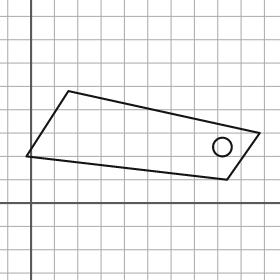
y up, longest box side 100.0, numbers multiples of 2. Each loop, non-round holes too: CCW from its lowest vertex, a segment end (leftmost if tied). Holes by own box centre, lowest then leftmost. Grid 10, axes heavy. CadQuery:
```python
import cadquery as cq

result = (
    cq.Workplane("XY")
    .moveTo(84.0, 10.0)
    .lineTo(98.0, 30.0)
    .lineTo(16.0, 48.0)
    .lineTo(-2.0, 20.0)
    .close()
    .moveTo(82.0, 24.0)
    .circle(4.0)
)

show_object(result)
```